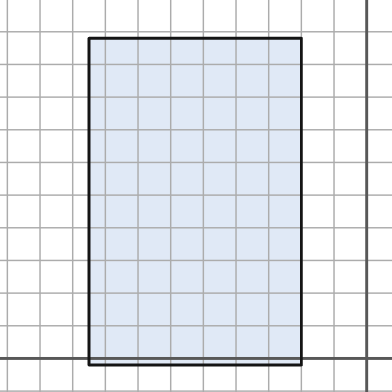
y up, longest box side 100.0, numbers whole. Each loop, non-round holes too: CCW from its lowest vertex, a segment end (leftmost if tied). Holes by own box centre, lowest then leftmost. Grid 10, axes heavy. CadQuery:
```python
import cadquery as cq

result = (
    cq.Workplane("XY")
    .moveTo(-85.0, -2.0)
    .lineTo(-20.0, -2.0)
    .lineTo(-20.0, 98.0)
    .lineTo(-85.0, 98.0)
    .close()
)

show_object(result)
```